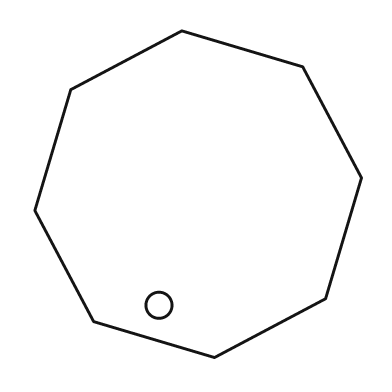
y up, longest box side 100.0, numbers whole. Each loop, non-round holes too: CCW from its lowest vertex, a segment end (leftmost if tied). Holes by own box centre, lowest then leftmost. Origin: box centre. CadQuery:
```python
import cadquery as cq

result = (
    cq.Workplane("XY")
    .moveTo(5.0, -50.0)
    .lineTo(39.0, -32.0)
    .lineTo(50.0, 5.0)
    .lineTo(32.0, 39.0)
    .lineTo(-5.0, 50.0)
    .lineTo(-39.0, 32.0)
    .lineTo(-50.0, -5.0)
    .lineTo(-32.0, -39.0)
    .close()
    .moveTo(-12.0, -34.0)
    .circle(4.0)
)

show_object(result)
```